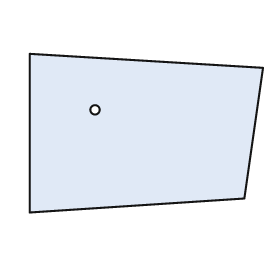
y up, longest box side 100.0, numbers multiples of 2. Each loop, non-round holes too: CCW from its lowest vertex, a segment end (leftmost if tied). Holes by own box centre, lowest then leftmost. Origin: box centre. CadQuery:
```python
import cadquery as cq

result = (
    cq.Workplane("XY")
    .moveTo(-50.0, -34.0)
    .lineTo(42.0, -28.0)
    .lineTo(50.0, 28.0)
    .lineTo(-50.0, 34.0)
    .close()
    .moveTo(-22.0, 10.0)
    .circle(2.0)
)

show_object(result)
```